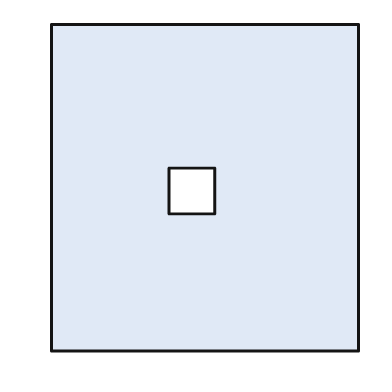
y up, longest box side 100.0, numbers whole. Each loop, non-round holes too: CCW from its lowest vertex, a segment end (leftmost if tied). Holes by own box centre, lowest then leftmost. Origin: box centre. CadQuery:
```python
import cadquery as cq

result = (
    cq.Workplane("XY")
    .moveTo(-47.0, -50.0)
    .lineTo(47.0, -50.0)
    .lineTo(47.0, 50.0)
    .lineTo(-47.0, 50.0)
    .close()
    .moveTo(-11.0, -8.0)
    .lineTo(3.0, -8.0)
    .lineTo(3.0, 6.0)
    .lineTo(-11.0, 6.0)
    .close()
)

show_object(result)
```